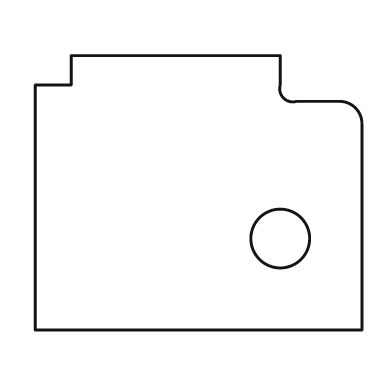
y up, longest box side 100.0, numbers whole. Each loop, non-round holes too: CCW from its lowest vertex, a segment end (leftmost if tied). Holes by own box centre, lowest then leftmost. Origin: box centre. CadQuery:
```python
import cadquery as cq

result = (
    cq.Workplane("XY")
    .moveTo(-50.0, -42.0)
    .lineTo(50.0, -42.0)
    .lineTo(50.0, 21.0)
    .threePointArc((48.0, 26.0), (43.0, 28.0))
    .lineTo(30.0, 28.0)
    .threePointArc((26.0, 29.0), (25.0, 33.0))
    .lineTo(25.0, 42.0)
    .lineTo(-39.0, 42.0)
    .lineTo(-39.0, 33.0)
    .lineTo(-50.0, 33.0)
    .close()
    .moveTo(25.0, -14.0)
    .circle(9.0)
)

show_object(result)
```